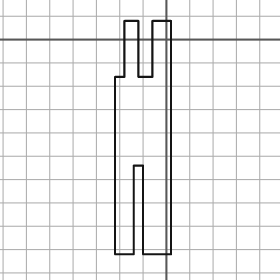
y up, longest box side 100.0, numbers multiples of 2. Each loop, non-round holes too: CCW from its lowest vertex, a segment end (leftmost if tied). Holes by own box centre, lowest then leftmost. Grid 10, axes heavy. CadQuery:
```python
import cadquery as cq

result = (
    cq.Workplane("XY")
    .moveTo(-22.0, -92.0)
    .lineTo(-14.0, -92.0)
    .lineTo(-14.0, -54.0)
    .lineTo(-10.0, -54.0)
    .lineTo(-10.0, -92.0)
    .lineTo(2.0, -92.0)
    .lineTo(2.0, 8.0)
    .lineTo(-6.0, 8.0)
    .lineTo(-6.0, -16.0)
    .lineTo(-12.0, -16.0)
    .lineTo(-12.0, 8.0)
    .lineTo(-18.0, 8.0)
    .lineTo(-18.0, -16.0)
    .lineTo(-22.0, -16.0)
    .close()
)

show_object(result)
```